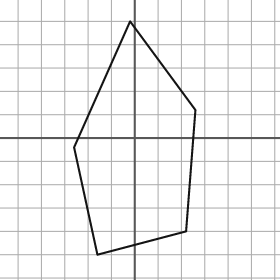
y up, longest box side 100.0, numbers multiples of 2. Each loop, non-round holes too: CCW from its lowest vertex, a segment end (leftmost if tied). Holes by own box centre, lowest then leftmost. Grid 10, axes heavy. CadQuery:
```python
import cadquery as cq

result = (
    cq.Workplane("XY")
    .moveTo(-16.0, -50.0)
    .lineTo(22.0, -40.0)
    .lineTo(26.0, 12.0)
    .lineTo(-2.0, 50.0)
    .lineTo(-26.0, -4.0)
    .close()
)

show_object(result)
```